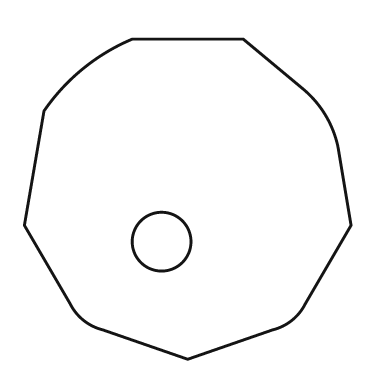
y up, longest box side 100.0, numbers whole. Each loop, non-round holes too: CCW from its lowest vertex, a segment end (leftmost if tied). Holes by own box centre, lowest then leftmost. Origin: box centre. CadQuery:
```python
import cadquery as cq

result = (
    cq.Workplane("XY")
    .moveTo(0.0, -49.0)
    .lineTo(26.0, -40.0)
    .threePointArc((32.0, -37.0), (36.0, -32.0))
    .lineTo(50.0, -8.0)
    .lineTo(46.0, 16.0)
    .threePointArc((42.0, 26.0), (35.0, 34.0))
    .lineTo(17.0, 49.0)
    .lineTo(-17.0, 49.0)
    .threePointArc((-32.0, 40.0), (-44.0, 27.0))
    .lineTo(-50.0, -8.0)
    .lineTo(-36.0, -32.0)
    .threePointArc((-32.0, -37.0), (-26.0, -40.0))
    .close()
    .moveTo(-8.0, -13.0)
    .circle(9.0)
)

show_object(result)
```